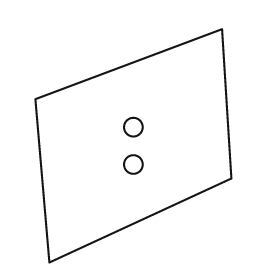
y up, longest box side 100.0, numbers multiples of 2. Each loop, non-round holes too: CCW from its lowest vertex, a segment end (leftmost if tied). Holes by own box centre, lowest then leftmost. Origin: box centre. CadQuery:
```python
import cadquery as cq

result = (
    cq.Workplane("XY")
    .moveTo(-36.0, -50.0)
    .lineTo(42.0, -14.0)
    .lineTo(38.0, 50.0)
    .lineTo(-42.0, 20.0)
    .close()
    .moveTo(0.0, -8.0)
    .circle(4.0)
    .moveTo(0.0, 8.0)
    .circle(4.0)
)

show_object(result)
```